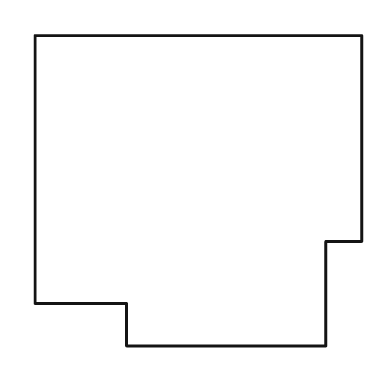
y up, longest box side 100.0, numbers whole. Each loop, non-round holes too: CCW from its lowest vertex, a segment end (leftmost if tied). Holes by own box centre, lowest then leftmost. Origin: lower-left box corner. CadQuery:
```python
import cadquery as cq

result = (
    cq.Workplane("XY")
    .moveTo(28.0, 0.0)
    .lineTo(89.0, 0.0)
    .lineTo(89.0, 32.0)
    .lineTo(100.0, 32.0)
    .lineTo(100.0, 95.0)
    .lineTo(0.0, 95.0)
    .lineTo(0.0, 13.0)
    .lineTo(28.0, 13.0)
    .close()
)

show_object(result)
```